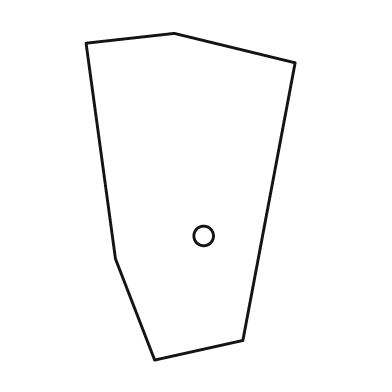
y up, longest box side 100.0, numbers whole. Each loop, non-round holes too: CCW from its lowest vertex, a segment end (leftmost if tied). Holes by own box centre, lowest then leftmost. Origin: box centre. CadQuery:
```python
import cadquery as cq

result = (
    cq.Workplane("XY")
    .moveTo(-11.0, -50.0)
    .lineTo(16.0, -44.0)
    .lineTo(32.0, 41.0)
    .lineTo(-5.0, 50.0)
    .lineTo(-32.0, 47.0)
    .lineTo(-23.0, -19.0)
    .close()
    .moveTo(4.0, -12.0)
    .circle(3.0)
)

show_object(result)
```